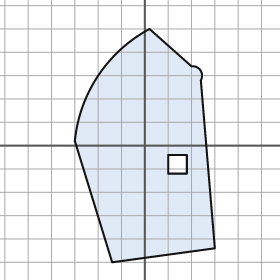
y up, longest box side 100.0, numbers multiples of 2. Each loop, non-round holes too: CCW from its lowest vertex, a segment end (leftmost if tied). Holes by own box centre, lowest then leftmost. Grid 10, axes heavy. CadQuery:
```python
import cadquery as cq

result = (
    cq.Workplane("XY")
    .moveTo(-14.0, -50.0)
    .lineTo(30.0, -44.0)
    .lineTo(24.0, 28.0)
    .threePointArc((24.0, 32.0), (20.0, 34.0))
    .lineTo(2.0, 50.0)
    .threePointArc((-20.0, 30.0), (-30.0, 2.0))
    .close()
    .moveTo(10.0, -12.0)
    .lineTo(18.0, -12.0)
    .lineTo(18.0, -4.0)
    .lineTo(10.0, -4.0)
    .close()
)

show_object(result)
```